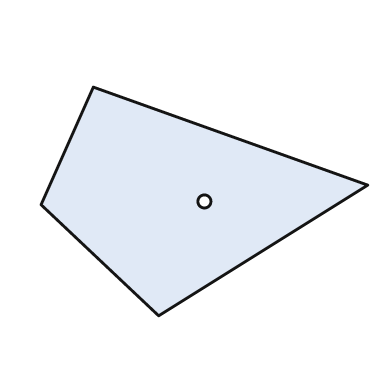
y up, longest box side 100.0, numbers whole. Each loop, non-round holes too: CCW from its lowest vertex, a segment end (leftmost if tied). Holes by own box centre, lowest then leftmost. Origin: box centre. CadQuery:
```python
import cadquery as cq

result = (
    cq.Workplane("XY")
    .moveTo(-14.0, -35.0)
    .lineTo(50.0, 5.0)
    .lineTo(-34.0, 35.0)
    .lineTo(-50.0, -1.0)
    .close()
    .moveTo(0.0, 0.0)
    .circle(2.0)
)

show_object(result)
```